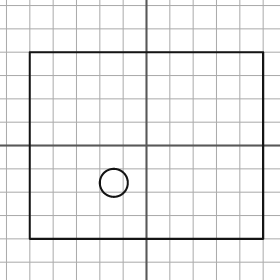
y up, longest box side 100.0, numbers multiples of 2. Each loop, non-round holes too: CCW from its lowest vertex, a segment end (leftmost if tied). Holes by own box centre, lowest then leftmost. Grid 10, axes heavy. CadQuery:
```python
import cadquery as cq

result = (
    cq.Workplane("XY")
    .moveTo(-50.0, -40.0)
    .lineTo(50.0, -40.0)
    .lineTo(50.0, 40.0)
    .lineTo(-50.0, 40.0)
    .close()
    .moveTo(-14.0, -16.0)
    .circle(6.0)
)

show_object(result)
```